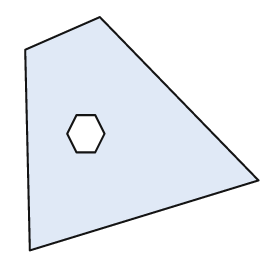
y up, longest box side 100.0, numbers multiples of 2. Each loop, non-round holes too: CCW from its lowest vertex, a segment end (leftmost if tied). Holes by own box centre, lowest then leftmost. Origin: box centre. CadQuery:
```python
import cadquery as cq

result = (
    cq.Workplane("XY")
    .moveTo(-48.0, -50.0)
    .lineTo(50.0, -20.0)
    .lineTo(-18.0, 50.0)
    .lineTo(-50.0, 36.0)
    .close()
    .moveTo(-28.0, -8.0)
    .lineTo(-20.0, -8.0)
    .lineTo(-16.0, 0.0)
    .lineTo(-20.0, 8.0)
    .lineTo(-28.0, 8.0)
    .lineTo(-32.0, 0.0)
    .close()
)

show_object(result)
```